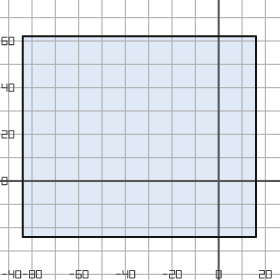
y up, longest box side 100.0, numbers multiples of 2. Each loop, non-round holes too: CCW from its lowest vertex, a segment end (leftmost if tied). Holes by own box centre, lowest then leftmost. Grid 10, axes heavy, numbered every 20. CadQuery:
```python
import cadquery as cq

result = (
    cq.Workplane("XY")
    .moveTo(-84.0, -24.0)
    .lineTo(16.0, -24.0)
    .lineTo(16.0, 62.0)
    .lineTo(-84.0, 62.0)
    .close()
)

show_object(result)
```